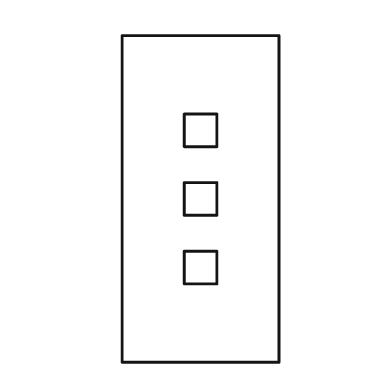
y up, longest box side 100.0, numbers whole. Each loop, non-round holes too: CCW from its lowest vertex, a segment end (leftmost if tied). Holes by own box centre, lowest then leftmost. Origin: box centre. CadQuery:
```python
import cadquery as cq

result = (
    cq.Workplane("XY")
    .moveTo(-24.0, -50.0)
    .lineTo(24.0, -50.0)
    .lineTo(24.0, 50.0)
    .lineTo(-24.0, 50.0)
    .close()
    .moveTo(-5.0, -26.0)
    .lineTo(5.0, -26.0)
    .lineTo(5.0, -16.0)
    .lineTo(-5.0, -16.0)
    .close()
    .moveTo(-5.0, -5.0)
    .lineTo(5.0, -5.0)
    .lineTo(5.0, 5.0)
    .lineTo(-5.0, 5.0)
    .close()
    .moveTo(-5.0, 16.0)
    .lineTo(5.0, 16.0)
    .lineTo(5.0, 26.0)
    .lineTo(-5.0, 26.0)
    .close()
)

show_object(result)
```